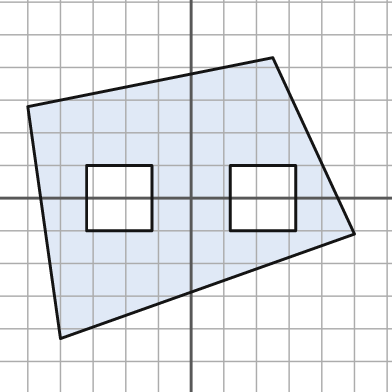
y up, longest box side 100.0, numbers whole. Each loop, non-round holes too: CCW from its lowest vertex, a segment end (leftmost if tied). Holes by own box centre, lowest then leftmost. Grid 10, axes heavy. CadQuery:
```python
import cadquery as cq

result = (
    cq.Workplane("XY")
    .moveTo(-40.0, -43.0)
    .lineTo(50.0, -11.0)
    .lineTo(25.0, 43.0)
    .lineTo(-50.0, 28.0)
    .close()
    .moveTo(-32.0, -10.0)
    .lineTo(-12.0, -10.0)
    .lineTo(-12.0, 10.0)
    .lineTo(-32.0, 10.0)
    .close()
    .moveTo(12.0, -10.0)
    .lineTo(32.0, -10.0)
    .lineTo(32.0, 10.0)
    .lineTo(12.0, 10.0)
    .close()
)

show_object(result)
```